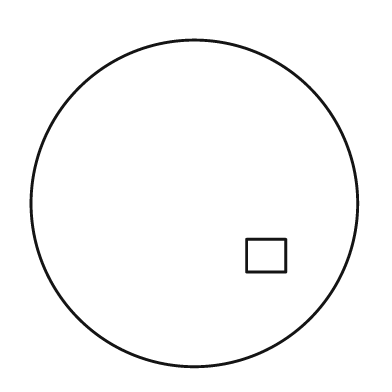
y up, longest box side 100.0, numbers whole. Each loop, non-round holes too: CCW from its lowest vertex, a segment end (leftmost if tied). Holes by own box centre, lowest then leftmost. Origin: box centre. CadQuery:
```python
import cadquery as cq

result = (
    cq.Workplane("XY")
    .moveTo(0.0, 0.0)
    .circle(50.0)
    .moveTo(16.0, -21.0)
    .lineTo(28.0, -21.0)
    .lineTo(28.0, -11.0)
    .lineTo(16.0, -11.0)
    .close()
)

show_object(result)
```